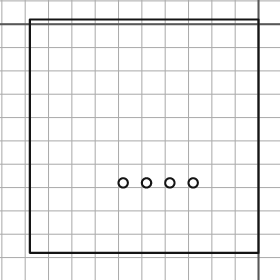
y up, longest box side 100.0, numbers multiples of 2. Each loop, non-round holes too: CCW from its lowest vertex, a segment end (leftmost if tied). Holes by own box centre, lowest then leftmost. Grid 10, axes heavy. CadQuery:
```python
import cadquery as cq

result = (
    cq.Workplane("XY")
    .moveTo(-98.0, -98.0)
    .lineTo(0.0, -98.0)
    .lineTo(0.0, 2.0)
    .lineTo(-98.0, 2.0)
    .close()
    .moveTo(-58.0, -68.0)
    .circle(2.0)
    .moveTo(-48.0, -68.0)
    .circle(2.0)
    .moveTo(-38.0, -68.0)
    .circle(2.0)
    .moveTo(-28.0, -68.0)
    .circle(2.0)
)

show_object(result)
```